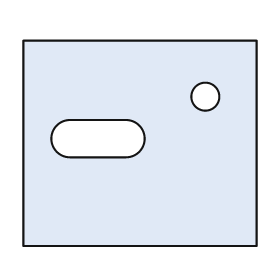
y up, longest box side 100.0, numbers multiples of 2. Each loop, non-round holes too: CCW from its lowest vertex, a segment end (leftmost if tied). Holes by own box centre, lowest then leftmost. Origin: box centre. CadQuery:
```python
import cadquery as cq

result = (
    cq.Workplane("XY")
    .moveTo(-50.0, -44.0)
    .lineTo(50.0, -44.0)
    .lineTo(50.0, 44.0)
    .lineTo(-50.0, 44.0)
    .close()
    .moveTo(-30.0, -6.0)
    .lineTo(-6.0, -6.0)
    .threePointArc((2.0, 2.0), (-6.0, 10.0))
    .lineTo(-30.0, 10.0)
    .threePointArc((-38.0, 2.0), (-30.0, -6.0))
    .close()
    .moveTo(28.0, 20.0)
    .circle(6.0)
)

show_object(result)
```